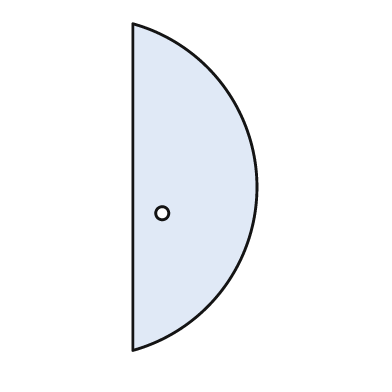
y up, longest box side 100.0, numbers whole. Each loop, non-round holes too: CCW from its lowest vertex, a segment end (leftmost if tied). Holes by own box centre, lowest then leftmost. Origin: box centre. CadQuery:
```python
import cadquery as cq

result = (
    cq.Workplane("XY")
    .moveTo(-19.0, -50.0)
    .threePointArc((19.0, 0.0), (-19.0, 50.0))
    .close()
    .moveTo(-10.0, -8.0)
    .circle(2.0)
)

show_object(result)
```